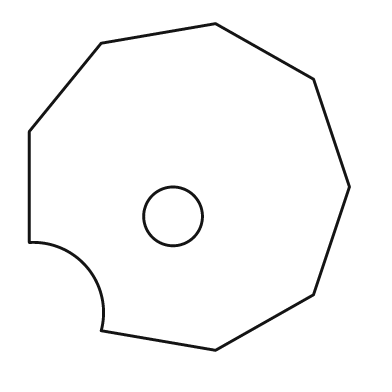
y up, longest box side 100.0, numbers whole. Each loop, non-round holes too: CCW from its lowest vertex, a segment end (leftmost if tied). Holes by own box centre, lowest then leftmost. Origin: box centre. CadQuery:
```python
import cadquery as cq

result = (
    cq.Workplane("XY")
    .moveTo(8.0, -50.0)
    .lineTo(38.0, -33.0)
    .lineTo(49.0, 0.0)
    .lineTo(38.0, 33.0)
    .lineTo(8.0, 50.0)
    .lineTo(-27.0, 44.0)
    .lineTo(-49.0, 17.0)
    .lineTo(-49.0, -17.0)
    .threePointArc((-31.0, -25.0), (-27.0, -44.0))
    .close()
    .moveTo(-5.0, -9.0)
    .circle(9.0)
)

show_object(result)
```